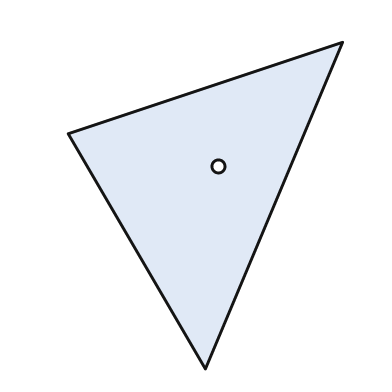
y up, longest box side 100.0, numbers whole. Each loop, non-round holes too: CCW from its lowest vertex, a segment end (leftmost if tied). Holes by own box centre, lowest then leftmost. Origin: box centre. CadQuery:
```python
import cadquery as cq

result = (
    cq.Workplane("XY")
    .moveTo(0.0, -50.0)
    .lineTo(42.0, 50.0)
    .lineTo(-42.0, 22.0)
    .close()
    .moveTo(4.0, 12.0)
    .circle(2.0)
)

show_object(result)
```